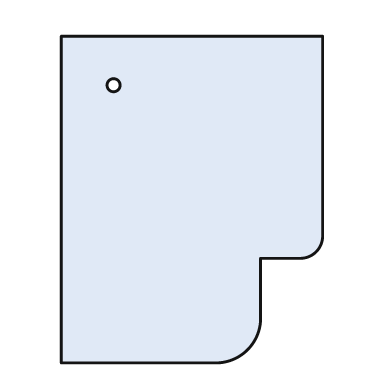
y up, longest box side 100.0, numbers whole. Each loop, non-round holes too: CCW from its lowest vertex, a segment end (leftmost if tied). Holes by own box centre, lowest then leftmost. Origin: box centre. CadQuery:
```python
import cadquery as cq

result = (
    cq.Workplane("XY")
    .moveTo(-40.0, -50.0)
    .lineTo(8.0, -50.0)
    .threePointArc((17.0, -46.0), (21.0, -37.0))
    .lineTo(21.0, -18.0)
    .lineTo(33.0, -18.0)
    .threePointArc((38.0, -16.0), (40.0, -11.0))
    .lineTo(40.0, 50.0)
    .lineTo(-40.0, 50.0)
    .close()
    .moveTo(-24.0, 35.0)
    .circle(2.0)
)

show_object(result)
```